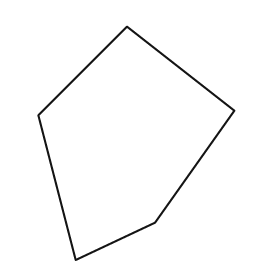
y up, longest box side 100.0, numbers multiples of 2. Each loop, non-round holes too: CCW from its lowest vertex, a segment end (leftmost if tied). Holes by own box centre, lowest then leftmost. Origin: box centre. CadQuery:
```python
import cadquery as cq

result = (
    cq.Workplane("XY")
    .moveTo(-26.0, -50.0)
    .lineTo(8.0, -34.0)
    .lineTo(42.0, 14.0)
    .lineTo(-4.0, 50.0)
    .lineTo(-42.0, 12.0)
    .close()
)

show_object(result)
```